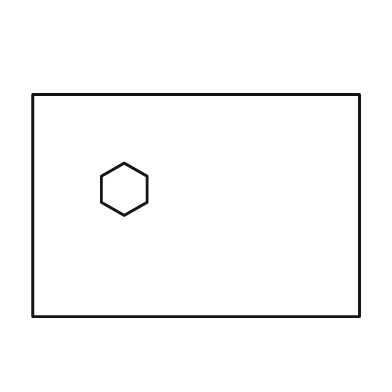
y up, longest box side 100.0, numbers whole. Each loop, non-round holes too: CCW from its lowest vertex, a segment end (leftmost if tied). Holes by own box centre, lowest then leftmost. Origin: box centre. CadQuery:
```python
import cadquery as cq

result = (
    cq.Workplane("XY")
    .moveTo(-50.0, -34.0)
    .lineTo(50.0, -34.0)
    .lineTo(50.0, 34.0)
    .lineTo(-50.0, 34.0)
    .close()
    .moveTo(-22.0, -3.0)
    .lineTo(-15.0, 1.0)
    .lineTo(-15.0, 9.0)
    .lineTo(-22.0, 13.0)
    .lineTo(-29.0, 9.0)
    .lineTo(-29.0, 1.0)
    .close()
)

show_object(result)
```